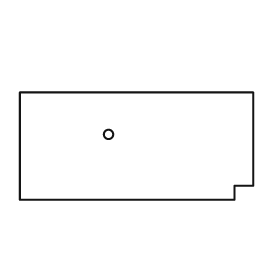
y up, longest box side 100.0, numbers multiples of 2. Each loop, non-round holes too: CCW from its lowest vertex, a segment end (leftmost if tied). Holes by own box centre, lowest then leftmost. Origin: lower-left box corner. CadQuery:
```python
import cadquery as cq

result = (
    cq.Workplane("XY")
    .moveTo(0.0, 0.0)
    .lineTo(92.0, 0.0)
    .lineTo(92.0, 6.0)
    .lineTo(100.0, 6.0)
    .lineTo(100.0, 46.0)
    .lineTo(0.0, 46.0)
    .close()
    .moveTo(38.0, 28.0)
    .circle(2.0)
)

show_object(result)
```